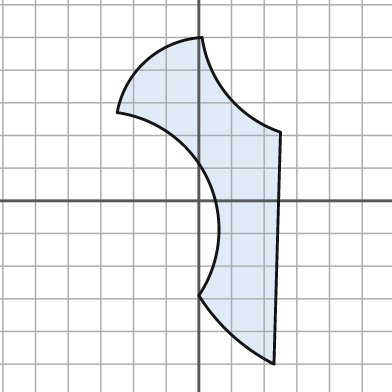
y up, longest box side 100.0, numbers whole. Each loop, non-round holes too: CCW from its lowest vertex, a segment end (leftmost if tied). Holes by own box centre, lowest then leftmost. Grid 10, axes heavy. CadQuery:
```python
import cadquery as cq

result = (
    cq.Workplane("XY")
    .moveTo(23.0, -50.0)
    .lineTo(25.0, 21.0)
    .threePointArc((9.0, 32.0), (1.0, 50.0))
    .threePointArc((-16.0, 43.0), (-25.0, 27.0))
    .threePointArc((3.0, 6.0), (0.0, -29.0))
    .threePointArc((10.0, -41.0), (23.0, -50.0))
    .close()
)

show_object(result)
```